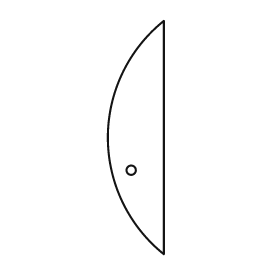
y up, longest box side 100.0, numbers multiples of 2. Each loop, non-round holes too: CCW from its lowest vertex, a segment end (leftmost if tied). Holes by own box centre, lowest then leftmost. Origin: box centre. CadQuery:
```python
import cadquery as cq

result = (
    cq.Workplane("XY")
    .moveTo(12.0, -50.0)
    .lineTo(12.0, 50.0)
    .threePointArc((-12.0, 0.0), (12.0, -50.0))
    .close()
    .moveTo(-2.0, -14.0)
    .circle(2.0)
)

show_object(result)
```